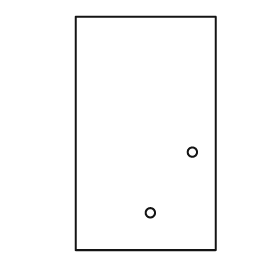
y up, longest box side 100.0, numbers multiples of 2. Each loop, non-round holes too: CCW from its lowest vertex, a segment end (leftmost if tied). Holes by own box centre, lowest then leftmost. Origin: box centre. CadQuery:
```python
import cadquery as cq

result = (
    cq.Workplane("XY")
    .moveTo(-30.0, -50.0)
    .lineTo(30.0, -50.0)
    .lineTo(30.0, 50.0)
    .lineTo(-30.0, 50.0)
    .close()
    .moveTo(2.0, -34.0)
    .circle(2.0)
    .moveTo(20.0, -8.0)
    .circle(2.0)
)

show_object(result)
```